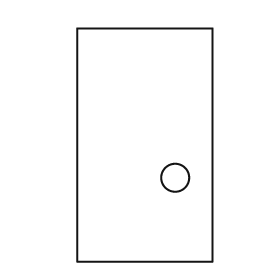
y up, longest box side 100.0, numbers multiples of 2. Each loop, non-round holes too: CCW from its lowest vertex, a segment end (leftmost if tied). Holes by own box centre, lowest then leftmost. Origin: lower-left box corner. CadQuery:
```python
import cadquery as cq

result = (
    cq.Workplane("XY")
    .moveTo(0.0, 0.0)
    .lineTo(58.0, 0.0)
    .lineTo(58.0, 100.0)
    .lineTo(0.0, 100.0)
    .close()
    .moveTo(42.0, 36.0)
    .circle(6.0)
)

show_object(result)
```